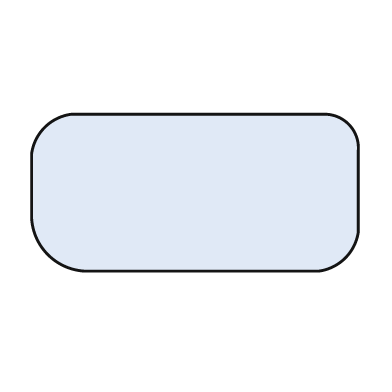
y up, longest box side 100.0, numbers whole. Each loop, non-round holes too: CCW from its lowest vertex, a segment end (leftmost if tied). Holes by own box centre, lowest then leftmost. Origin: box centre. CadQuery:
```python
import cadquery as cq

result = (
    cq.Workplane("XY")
    .moveTo(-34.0, -24.0)
    .lineTo(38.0, -24.0)
    .threePointArc((46.0, -20.0), (50.0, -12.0))
    .lineTo(50.0, 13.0)
    .threePointArc((47.0, 21.0), (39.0, 24.0))
    .lineTo(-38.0, 24.0)
    .threePointArc((-46.0, 20.0), (-50.0, 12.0))
    .lineTo(-50.0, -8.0)
    .threePointArc((-45.0, -19.0), (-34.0, -24.0))
    .close()
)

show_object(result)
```